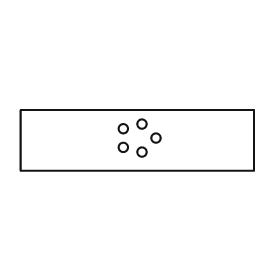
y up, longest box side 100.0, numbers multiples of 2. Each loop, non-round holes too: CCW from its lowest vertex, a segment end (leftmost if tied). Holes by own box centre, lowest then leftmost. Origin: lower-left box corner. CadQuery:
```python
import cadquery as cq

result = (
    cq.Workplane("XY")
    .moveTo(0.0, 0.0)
    .lineTo(100.0, 0.0)
    .lineTo(100.0, 26.0)
    .lineTo(0.0, 26.0)
    .close()
    .moveTo(52.0, 8.0)
    .circle(2.0)
    .moveTo(44.0, 10.0)
    .circle(2.0)
    .moveTo(58.0, 14.0)
    .circle(2.0)
    .moveTo(44.0, 18.0)
    .circle(2.0)
    .moveTo(52.0, 20.0)
    .circle(2.0)
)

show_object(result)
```